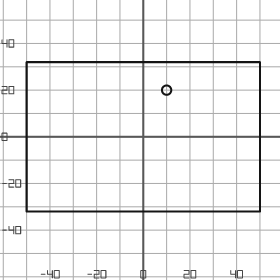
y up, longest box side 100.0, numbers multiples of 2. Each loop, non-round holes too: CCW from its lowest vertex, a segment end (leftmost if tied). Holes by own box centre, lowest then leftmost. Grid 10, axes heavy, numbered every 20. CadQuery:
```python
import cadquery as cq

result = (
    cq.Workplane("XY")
    .moveTo(-50.0, -32.0)
    .lineTo(50.0, -32.0)
    .lineTo(50.0, 32.0)
    .lineTo(-50.0, 32.0)
    .close()
    .moveTo(10.0, 20.0)
    .circle(2.0)
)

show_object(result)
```